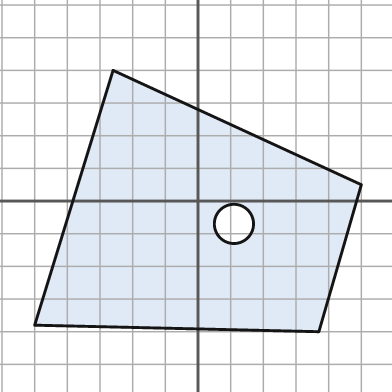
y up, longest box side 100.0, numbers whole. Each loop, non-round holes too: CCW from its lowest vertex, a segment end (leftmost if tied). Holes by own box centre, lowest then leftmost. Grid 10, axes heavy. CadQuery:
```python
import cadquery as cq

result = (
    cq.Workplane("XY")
    .moveTo(37.0, -40.0)
    .lineTo(50.0, 5.0)
    .lineTo(-26.0, 40.0)
    .lineTo(-50.0, -38.0)
    .close()
    .moveTo(11.0, -7.0)
    .circle(6.0)
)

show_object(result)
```